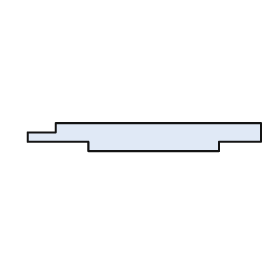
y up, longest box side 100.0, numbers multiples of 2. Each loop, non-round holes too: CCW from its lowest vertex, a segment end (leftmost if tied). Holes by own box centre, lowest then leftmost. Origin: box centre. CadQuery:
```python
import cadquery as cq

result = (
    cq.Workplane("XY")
    .moveTo(-24.0, -6.0)
    .lineTo(32.0, -6.0)
    .lineTo(32.0, -2.0)
    .lineTo(50.0, -2.0)
    .lineTo(50.0, 6.0)
    .lineTo(-38.0, 6.0)
    .lineTo(-38.0, 2.0)
    .lineTo(-50.0, 2.0)
    .lineTo(-50.0, -2.0)
    .lineTo(-24.0, -2.0)
    .close()
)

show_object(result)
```